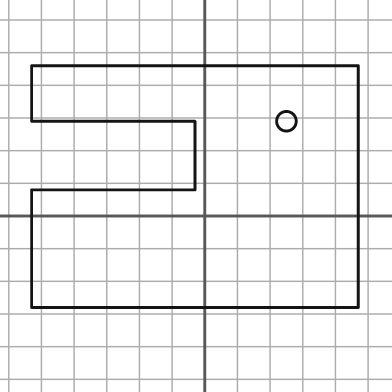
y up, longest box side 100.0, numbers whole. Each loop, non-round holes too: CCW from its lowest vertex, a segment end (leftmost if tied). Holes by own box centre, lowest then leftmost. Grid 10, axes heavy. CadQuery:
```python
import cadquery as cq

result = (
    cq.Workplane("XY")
    .moveTo(-53.0, -28.0)
    .lineTo(47.0, -28.0)
    .lineTo(47.0, 46.0)
    .lineTo(-53.0, 46.0)
    .lineTo(-53.0, 29.0)
    .lineTo(-3.0, 29.0)
    .lineTo(-3.0, 8.0)
    .lineTo(-53.0, 8.0)
    .close()
    .moveTo(25.0, 29.0)
    .circle(3.0)
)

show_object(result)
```